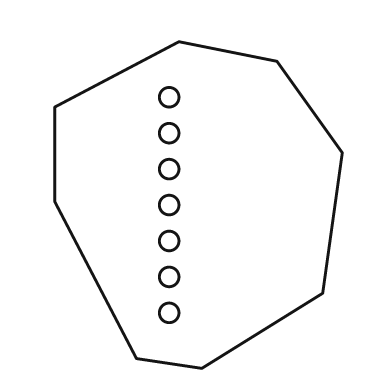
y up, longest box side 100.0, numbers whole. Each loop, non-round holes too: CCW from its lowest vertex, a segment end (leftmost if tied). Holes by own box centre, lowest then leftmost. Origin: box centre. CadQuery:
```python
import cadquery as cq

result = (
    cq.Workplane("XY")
    .moveTo(1.0, -50.0)
    .lineTo(38.0, -27.0)
    .lineTo(44.0, 16.0)
    .lineTo(24.0, 44.0)
    .lineTo(-6.0, 50.0)
    .lineTo(-44.0, 30.0)
    .lineTo(-44.0, 1.0)
    .lineTo(-19.0, -47.0)
    .close()
    .moveTo(-9.0, -33.0)
    .circle(3.0)
    .moveTo(-9.0, -22.0)
    .circle(3.0)
    .moveTo(-9.0, -11.0)
    .circle(3.0)
    .moveTo(-9.0, 0.0)
    .circle(3.0)
    .moveTo(-9.0, 11.0)
    .circle(3.0)
    .moveTo(-9.0, 22.0)
    .circle(3.0)
    .moveTo(-9.0, 33.0)
    .circle(3.0)
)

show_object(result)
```